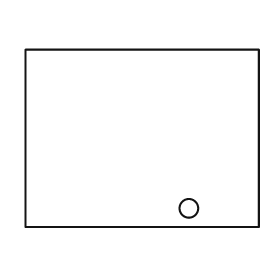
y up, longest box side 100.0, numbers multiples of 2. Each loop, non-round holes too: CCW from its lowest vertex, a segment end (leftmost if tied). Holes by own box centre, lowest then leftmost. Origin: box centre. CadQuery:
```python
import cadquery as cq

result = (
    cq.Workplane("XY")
    .moveTo(-50.0, -38.0)
    .lineTo(50.0, -38.0)
    .lineTo(50.0, 38.0)
    .lineTo(-50.0, 38.0)
    .close()
    .moveTo(20.0, -30.0)
    .circle(4.0)
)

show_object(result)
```